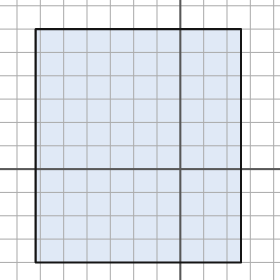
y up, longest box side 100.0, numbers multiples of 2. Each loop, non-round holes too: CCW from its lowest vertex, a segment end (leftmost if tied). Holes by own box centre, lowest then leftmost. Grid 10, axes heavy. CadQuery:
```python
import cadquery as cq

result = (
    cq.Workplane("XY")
    .moveTo(-62.0, -40.0)
    .lineTo(26.0, -40.0)
    .lineTo(26.0, 60.0)
    .lineTo(-62.0, 60.0)
    .close()
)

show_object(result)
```